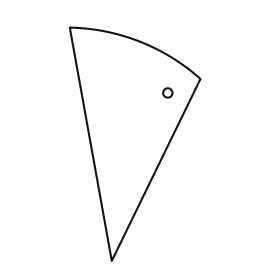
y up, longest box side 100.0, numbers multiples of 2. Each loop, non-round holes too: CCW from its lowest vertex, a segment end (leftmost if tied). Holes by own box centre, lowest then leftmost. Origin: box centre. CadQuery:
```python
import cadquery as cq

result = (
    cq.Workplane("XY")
    .moveTo(-10.0, -50.0)
    .lineTo(28.0, 28.0)
    .threePointArc((2.0, 44.0), (-28.0, 50.0))
    .close()
    .moveTo(14.0, 22.0)
    .circle(2.0)
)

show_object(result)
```